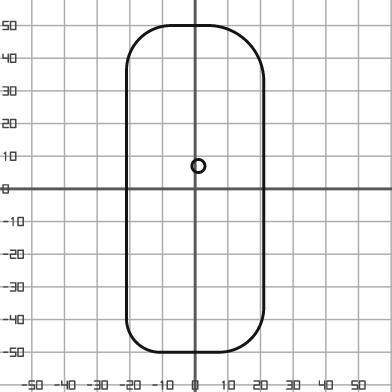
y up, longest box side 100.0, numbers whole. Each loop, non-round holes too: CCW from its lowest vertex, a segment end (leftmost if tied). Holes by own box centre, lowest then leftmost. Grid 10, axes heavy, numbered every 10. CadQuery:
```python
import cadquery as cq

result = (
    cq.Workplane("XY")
    .moveTo(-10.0, -50.0)
    .lineTo(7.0, -50.0)
    .threePointArc((17.0, -46.0), (21.0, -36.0))
    .lineTo(21.0, 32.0)
    .threePointArc((16.0, 45.0), (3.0, 50.0))
    .lineTo(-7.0, 50.0)
    .threePointArc((-17.0, 46.0), (-21.0, 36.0))
    .lineTo(-21.0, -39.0)
    .threePointArc((-18.0, -47.0), (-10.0, -50.0))
    .close()
    .moveTo(1.0, 7.0)
    .circle(2.0)
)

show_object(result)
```